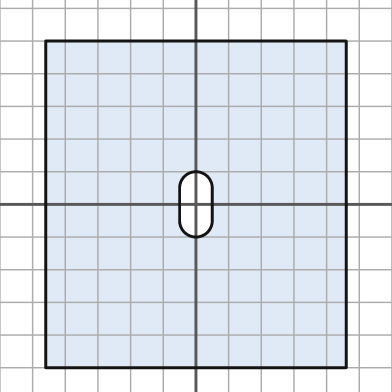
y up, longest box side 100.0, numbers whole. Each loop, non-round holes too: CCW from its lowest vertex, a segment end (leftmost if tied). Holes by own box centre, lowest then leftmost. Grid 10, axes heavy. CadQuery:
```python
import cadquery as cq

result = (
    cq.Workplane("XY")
    .moveTo(-46.0, -50.0)
    .lineTo(46.0, -50.0)
    .lineTo(46.0, 50.0)
    .lineTo(-46.0, 50.0)
    .close()
    .moveTo(-5.0, -5.0)
    .threePointArc((0.0, -10.0), (5.0, -5.0))
    .lineTo(5.0, 5.0)
    .threePointArc((0.0, 10.0), (-5.0, 5.0))
    .close()
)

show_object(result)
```